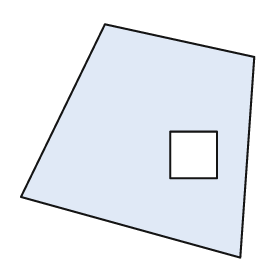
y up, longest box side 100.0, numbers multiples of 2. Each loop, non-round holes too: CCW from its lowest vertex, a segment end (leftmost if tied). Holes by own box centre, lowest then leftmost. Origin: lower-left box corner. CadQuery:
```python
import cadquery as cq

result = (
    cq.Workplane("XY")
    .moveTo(94.0, 0.0)
    .lineTo(100.0, 86.0)
    .lineTo(36.0, 100.0)
    .lineTo(0.0, 26.0)
    .close()
    .moveTo(64.0, 34.0)
    .lineTo(84.0, 34.0)
    .lineTo(84.0, 54.0)
    .lineTo(64.0, 54.0)
    .close()
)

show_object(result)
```